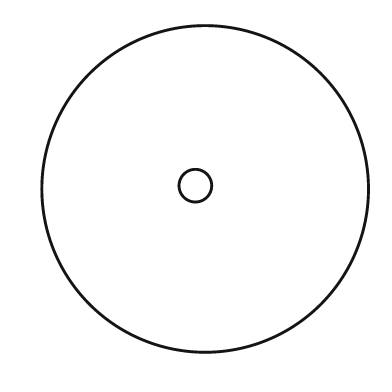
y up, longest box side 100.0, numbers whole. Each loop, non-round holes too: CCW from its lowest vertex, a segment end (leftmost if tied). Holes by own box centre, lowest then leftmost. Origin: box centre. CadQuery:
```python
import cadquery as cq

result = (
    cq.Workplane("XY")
    .moveTo(0.0, 0.0)
    .circle(50.0)
    .moveTo(-3.0, 1.0)
    .circle(5.0)
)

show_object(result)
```